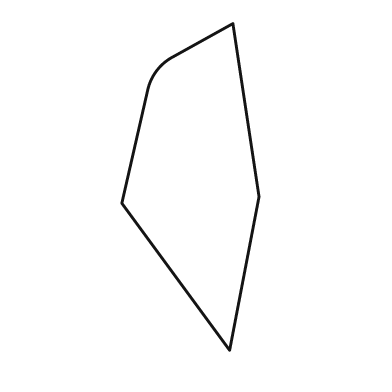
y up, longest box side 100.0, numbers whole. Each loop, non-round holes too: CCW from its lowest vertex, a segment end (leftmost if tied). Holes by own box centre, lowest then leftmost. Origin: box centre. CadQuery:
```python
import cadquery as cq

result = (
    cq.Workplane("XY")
    .moveTo(12.0, -50.0)
    .lineTo(21.0, -3.0)
    .lineTo(13.0, 50.0)
    .lineTo(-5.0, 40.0)
    .threePointArc((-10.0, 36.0), (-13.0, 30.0))
    .lineTo(-21.0, -5.0)
    .close()
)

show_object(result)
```